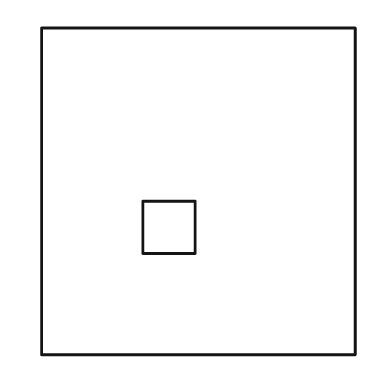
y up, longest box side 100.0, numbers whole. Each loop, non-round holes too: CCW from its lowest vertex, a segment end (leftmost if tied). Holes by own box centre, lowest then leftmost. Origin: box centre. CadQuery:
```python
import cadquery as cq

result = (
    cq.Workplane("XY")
    .moveTo(-48.0, -50.0)
    .lineTo(48.0, -50.0)
    .lineTo(48.0, 50.0)
    .lineTo(-48.0, 50.0)
    .close()
    .moveTo(-17.0, -19.0)
    .lineTo(-1.0, -19.0)
    .lineTo(-1.0, -3.0)
    .lineTo(-17.0, -3.0)
    .close()
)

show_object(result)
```